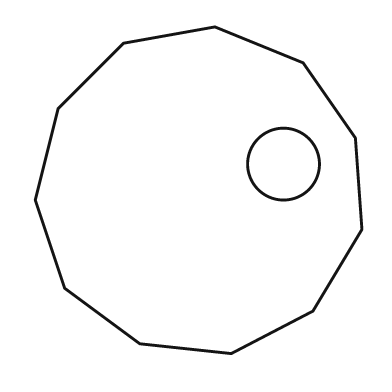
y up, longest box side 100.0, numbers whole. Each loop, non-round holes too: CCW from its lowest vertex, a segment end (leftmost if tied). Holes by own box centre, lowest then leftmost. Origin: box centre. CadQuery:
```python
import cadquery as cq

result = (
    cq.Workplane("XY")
    .moveTo(10.0, -50.0)
    .lineTo(35.0, -37.0)
    .lineTo(50.0, -12.0)
    .lineTo(48.0, 16.0)
    .lineTo(32.0, 39.0)
    .lineTo(5.0, 50.0)
    .lineTo(-23.0, 45.0)
    .lineTo(-43.0, 25.0)
    .lineTo(-50.0, -3.0)
    .lineTo(-41.0, -30.0)
    .lineTo(-18.0, -47.0)
    .close()
    .moveTo(26.0, 8.0)
    .circle(11.0)
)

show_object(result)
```